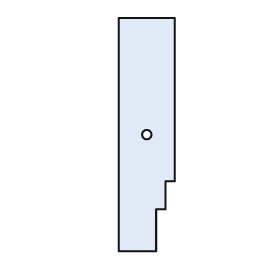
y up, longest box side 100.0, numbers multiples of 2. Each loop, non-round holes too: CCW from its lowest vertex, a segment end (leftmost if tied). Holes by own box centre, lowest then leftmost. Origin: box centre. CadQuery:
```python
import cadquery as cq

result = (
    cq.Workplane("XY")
    .moveTo(-12.0, -50.0)
    .lineTo(4.0, -50.0)
    .lineTo(4.0, -32.0)
    .lineTo(8.0, -32.0)
    .lineTo(8.0, -20.0)
    .lineTo(12.0, -20.0)
    .lineTo(12.0, 50.0)
    .lineTo(-12.0, 50.0)
    .close()
    .moveTo(0.0, 0.0)
    .circle(2.0)
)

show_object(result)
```